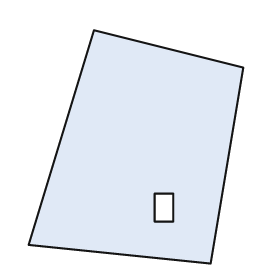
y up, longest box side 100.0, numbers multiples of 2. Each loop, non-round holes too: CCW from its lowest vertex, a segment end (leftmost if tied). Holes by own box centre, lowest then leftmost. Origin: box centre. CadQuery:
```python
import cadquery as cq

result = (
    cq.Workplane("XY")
    .moveTo(32.0, -50.0)
    .lineTo(46.0, 34.0)
    .lineTo(-18.0, 50.0)
    .lineTo(-46.0, -42.0)
    .close()
    .moveTo(8.0, -32.0)
    .lineTo(16.0, -32.0)
    .lineTo(16.0, -20.0)
    .lineTo(8.0, -20.0)
    .close()
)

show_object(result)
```